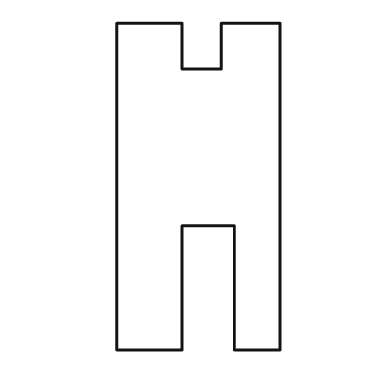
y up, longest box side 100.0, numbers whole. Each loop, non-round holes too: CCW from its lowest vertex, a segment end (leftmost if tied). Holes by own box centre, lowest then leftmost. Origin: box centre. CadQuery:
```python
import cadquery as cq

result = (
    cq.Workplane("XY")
    .moveTo(-25.0, -50.0)
    .lineTo(-5.0, -50.0)
    .lineTo(-5.0, -12.0)
    .lineTo(11.0, -12.0)
    .lineTo(11.0, -50.0)
    .lineTo(25.0, -50.0)
    .lineTo(25.0, 50.0)
    .lineTo(7.0, 50.0)
    .lineTo(7.0, 36.0)
    .lineTo(-5.0, 36.0)
    .lineTo(-5.0, 50.0)
    .lineTo(-25.0, 50.0)
    .close()
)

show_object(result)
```